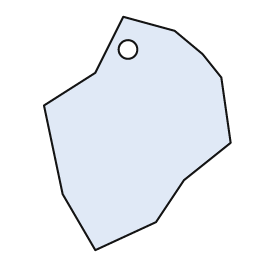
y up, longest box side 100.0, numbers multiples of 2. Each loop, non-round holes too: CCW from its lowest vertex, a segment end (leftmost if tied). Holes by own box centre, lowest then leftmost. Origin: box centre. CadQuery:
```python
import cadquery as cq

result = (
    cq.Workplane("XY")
    .moveTo(-18.0, -50.0)
    .lineTo(8.0, -38.0)
    .lineTo(20.0, -20.0)
    .lineTo(40.0, -4.0)
    .lineTo(36.0, 24.0)
    .lineTo(28.0, 34.0)
    .lineTo(16.0, 44.0)
    .lineTo(-6.0, 50.0)
    .lineTo(-18.0, 26.0)
    .lineTo(-40.0, 12.0)
    .lineTo(-32.0, -26.0)
    .close()
    .moveTo(-4.0, 36.0)
    .circle(4.0)
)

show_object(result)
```